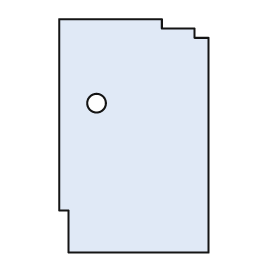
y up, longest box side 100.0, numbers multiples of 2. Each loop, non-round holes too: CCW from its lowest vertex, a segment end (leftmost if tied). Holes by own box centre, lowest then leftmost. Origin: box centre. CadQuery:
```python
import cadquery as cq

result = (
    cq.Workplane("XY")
    .moveTo(-28.0, -50.0)
    .lineTo(32.0, -50.0)
    .lineTo(32.0, 42.0)
    .lineTo(26.0, 42.0)
    .lineTo(26.0, 46.0)
    .lineTo(12.0, 46.0)
    .lineTo(12.0, 50.0)
    .lineTo(-32.0, 50.0)
    .lineTo(-32.0, -32.0)
    .lineTo(-28.0, -32.0)
    .close()
    .moveTo(-16.0, 14.0)
    .circle(4.0)
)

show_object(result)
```